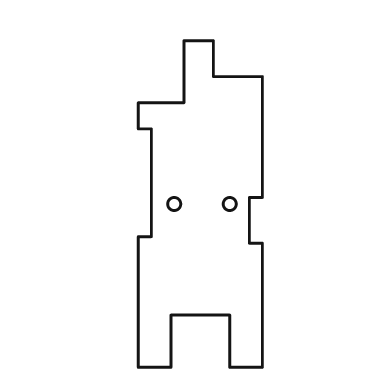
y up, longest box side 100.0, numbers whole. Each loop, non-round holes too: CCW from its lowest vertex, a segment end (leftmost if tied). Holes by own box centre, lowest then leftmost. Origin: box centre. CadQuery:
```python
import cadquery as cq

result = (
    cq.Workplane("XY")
    .moveTo(-19.0, -50.0)
    .lineTo(-9.0, -50.0)
    .lineTo(-9.0, -34.0)
    .lineTo(9.0, -34.0)
    .lineTo(9.0, -50.0)
    .lineTo(19.0, -50.0)
    .lineTo(19.0, -12.0)
    .lineTo(15.0, -12.0)
    .lineTo(15.0, 2.0)
    .lineTo(19.0, 2.0)
    .lineTo(19.0, 39.0)
    .lineTo(4.0, 39.0)
    .lineTo(4.0, 50.0)
    .lineTo(-5.0, 50.0)
    .lineTo(-5.0, 31.0)
    .lineTo(-19.0, 31.0)
    .lineTo(-19.0, 23.0)
    .lineTo(-15.0, 23.0)
    .lineTo(-15.0, -10.0)
    .lineTo(-19.0, -10.0)
    .close()
    .moveTo(-8.0, 0.0)
    .circle(2.0)
    .moveTo(9.0, 0.0)
    .circle(2.0)
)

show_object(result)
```